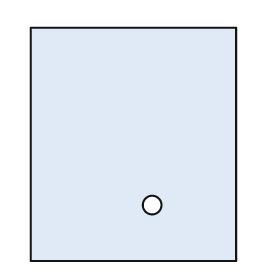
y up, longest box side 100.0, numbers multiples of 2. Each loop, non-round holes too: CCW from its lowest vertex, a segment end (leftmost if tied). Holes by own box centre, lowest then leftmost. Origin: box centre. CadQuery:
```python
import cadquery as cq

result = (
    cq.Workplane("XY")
    .moveTo(-44.0, -50.0)
    .lineTo(44.0, -50.0)
    .lineTo(44.0, 50.0)
    .lineTo(-44.0, 50.0)
    .close()
    .moveTo(8.0, -26.0)
    .circle(4.0)
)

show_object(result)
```